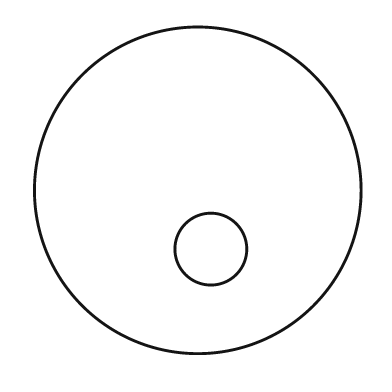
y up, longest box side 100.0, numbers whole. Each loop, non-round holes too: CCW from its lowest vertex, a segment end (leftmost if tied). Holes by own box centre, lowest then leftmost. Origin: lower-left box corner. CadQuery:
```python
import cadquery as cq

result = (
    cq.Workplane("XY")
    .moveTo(50.0, 50.0)
    .circle(50.0)
    .moveTo(54.0, 32.0)
    .circle(11.0)
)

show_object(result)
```